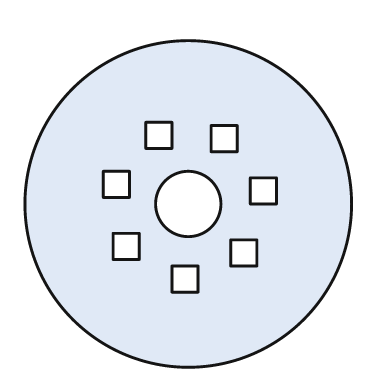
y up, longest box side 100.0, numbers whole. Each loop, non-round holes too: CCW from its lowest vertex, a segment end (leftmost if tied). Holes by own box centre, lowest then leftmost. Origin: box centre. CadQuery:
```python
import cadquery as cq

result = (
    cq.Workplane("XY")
    .moveTo(0.0, 0.0)
    .circle(50.0)
    .moveTo(-5.0, -27.0)
    .lineTo(3.0, -27.0)
    .lineTo(3.0, -19.0)
    .lineTo(-5.0, -19.0)
    .close()
    .moveTo(13.0, -19.0)
    .lineTo(21.0, -19.0)
    .lineTo(21.0, -11.0)
    .lineTo(13.0, -11.0)
    .close()
    .moveTo(-23.0, -17.0)
    .lineTo(-15.0, -17.0)
    .lineTo(-15.0, -9.0)
    .lineTo(-23.0, -9.0)
    .close()
    .moveTo(0.0, 0.0)
    .circle(10.0)
    .moveTo(19.0, 0.0)
    .lineTo(27.0, 0.0)
    .lineTo(27.0, 8.0)
    .lineTo(19.0, 8.0)
    .close()
    .moveTo(-26.0, 2.0)
    .lineTo(-18.0, 2.0)
    .lineTo(-18.0, 10.0)
    .lineTo(-26.0, 10.0)
    .close()
    .moveTo(7.0, 16.0)
    .lineTo(15.0, 16.0)
    .lineTo(15.0, 24.0)
    .lineTo(7.0, 24.0)
    .close()
    .moveTo(-13.0, 17.0)
    .lineTo(-5.0, 17.0)
    .lineTo(-5.0, 25.0)
    .lineTo(-13.0, 25.0)
    .close()
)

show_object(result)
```